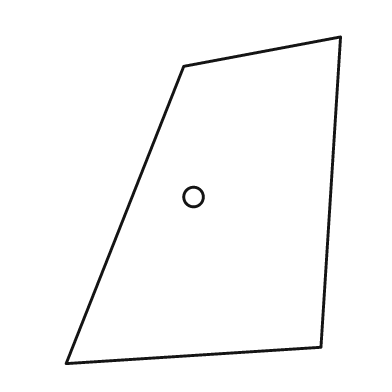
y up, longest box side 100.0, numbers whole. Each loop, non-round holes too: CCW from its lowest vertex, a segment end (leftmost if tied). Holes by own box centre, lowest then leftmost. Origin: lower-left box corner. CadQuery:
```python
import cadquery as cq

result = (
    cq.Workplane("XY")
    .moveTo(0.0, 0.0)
    .lineTo(78.0, 5.0)
    .lineTo(84.0, 100.0)
    .lineTo(36.0, 91.0)
    .close()
    .moveTo(39.0, 51.0)
    .circle(3.0)
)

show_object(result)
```